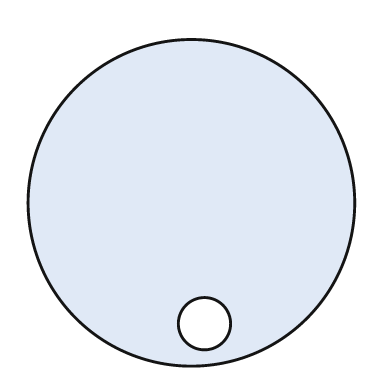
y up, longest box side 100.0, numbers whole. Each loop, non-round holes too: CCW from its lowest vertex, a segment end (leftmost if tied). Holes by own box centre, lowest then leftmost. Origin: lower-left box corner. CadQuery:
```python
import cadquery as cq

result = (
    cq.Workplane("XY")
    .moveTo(50.0, 50.0)
    .circle(50.0)
    .moveTo(54.0, 13.0)
    .circle(8.0)
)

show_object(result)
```